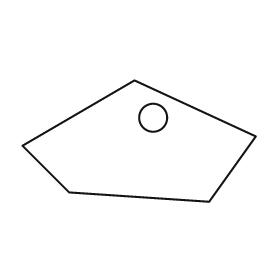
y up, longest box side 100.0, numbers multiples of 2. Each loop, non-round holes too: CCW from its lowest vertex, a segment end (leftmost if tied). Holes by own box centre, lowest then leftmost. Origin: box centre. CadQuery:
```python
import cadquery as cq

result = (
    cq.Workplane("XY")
    .moveTo(30.0, -26.0)
    .lineTo(50.0, 2.0)
    .lineTo(-2.0, 26.0)
    .lineTo(-50.0, -2.0)
    .lineTo(-30.0, -22.0)
    .close()
    .moveTo(6.0, 10.0)
    .circle(6.0)
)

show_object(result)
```